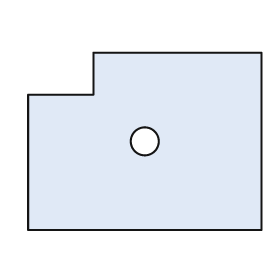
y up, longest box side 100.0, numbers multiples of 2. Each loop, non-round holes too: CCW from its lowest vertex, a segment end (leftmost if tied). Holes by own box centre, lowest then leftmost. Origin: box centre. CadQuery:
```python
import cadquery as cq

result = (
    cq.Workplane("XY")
    .moveTo(-50.0, -38.0)
    .lineTo(50.0, -38.0)
    .lineTo(50.0, 38.0)
    .lineTo(-22.0, 38.0)
    .lineTo(-22.0, 20.0)
    .lineTo(-50.0, 20.0)
    .close()
    .moveTo(0.0, 0.0)
    .circle(6.0)
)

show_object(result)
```